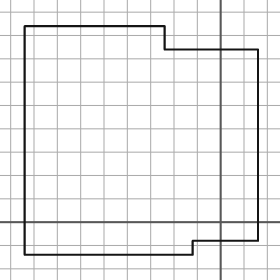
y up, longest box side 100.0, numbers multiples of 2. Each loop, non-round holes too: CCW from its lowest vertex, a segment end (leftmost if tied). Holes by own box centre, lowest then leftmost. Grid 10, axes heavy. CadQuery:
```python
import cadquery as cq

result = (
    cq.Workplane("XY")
    .moveTo(-84.0, -14.0)
    .lineTo(-12.0, -14.0)
    .lineTo(-12.0, -8.0)
    .lineTo(16.0, -8.0)
    .lineTo(16.0, 74.0)
    .lineTo(-24.0, 74.0)
    .lineTo(-24.0, 84.0)
    .lineTo(-84.0, 84.0)
    .close()
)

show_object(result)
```